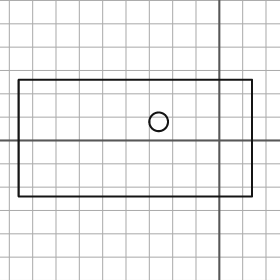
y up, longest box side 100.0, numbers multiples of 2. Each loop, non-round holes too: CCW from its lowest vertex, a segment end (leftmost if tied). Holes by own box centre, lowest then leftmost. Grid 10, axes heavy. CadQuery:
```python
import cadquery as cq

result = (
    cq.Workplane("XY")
    .moveTo(-86.0, -24.0)
    .lineTo(14.0, -24.0)
    .lineTo(14.0, 26.0)
    .lineTo(-86.0, 26.0)
    .close()
    .moveTo(-26.0, 8.0)
    .circle(4.0)
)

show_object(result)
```